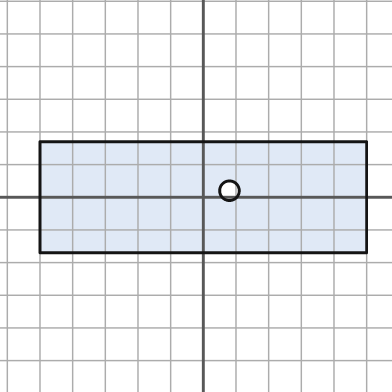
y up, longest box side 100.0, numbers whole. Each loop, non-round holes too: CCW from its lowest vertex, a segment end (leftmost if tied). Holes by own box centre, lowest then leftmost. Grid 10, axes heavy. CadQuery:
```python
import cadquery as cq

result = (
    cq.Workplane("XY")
    .moveTo(-50.0, -17.0)
    .lineTo(50.0, -17.0)
    .lineTo(50.0, 17.0)
    .lineTo(-50.0, 17.0)
    .close()
    .moveTo(8.0, 2.0)
    .circle(3.0)
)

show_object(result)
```